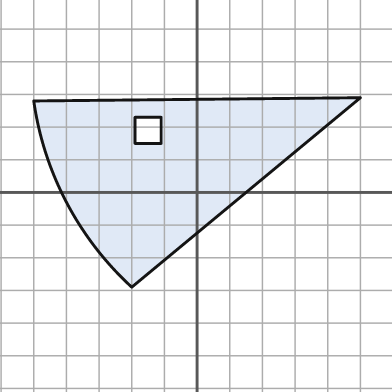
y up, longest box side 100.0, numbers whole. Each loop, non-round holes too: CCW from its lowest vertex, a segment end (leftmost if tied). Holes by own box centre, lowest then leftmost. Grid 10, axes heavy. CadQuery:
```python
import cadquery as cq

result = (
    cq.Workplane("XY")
    .moveTo(-20.0, -29.0)
    .lineTo(50.0, 29.0)
    .lineTo(-50.0, 28.0)
    .threePointArc((-40.0, -3.0), (-20.0, -29.0))
    .close()
    .moveTo(-19.0, 15.0)
    .lineTo(-11.0, 15.0)
    .lineTo(-11.0, 23.0)
    .lineTo(-19.0, 23.0)
    .close()
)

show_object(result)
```